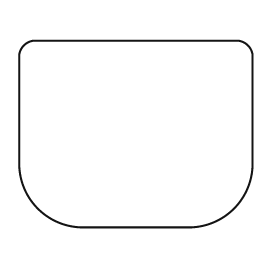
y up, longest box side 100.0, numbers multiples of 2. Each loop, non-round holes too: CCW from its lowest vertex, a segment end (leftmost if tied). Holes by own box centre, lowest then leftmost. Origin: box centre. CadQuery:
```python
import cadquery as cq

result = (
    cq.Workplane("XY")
    .moveTo(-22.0, -40.0)
    .lineTo(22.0, -40.0)
    .threePointArc((42.0, -32.0), (50.0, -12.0))
    .lineTo(50.0, 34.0)
    .threePointArc((48.0, 38.0), (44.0, 40.0))
    .lineTo(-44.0, 40.0)
    .threePointArc((-48.0, 38.0), (-50.0, 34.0))
    .lineTo(-50.0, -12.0)
    .threePointArc((-42.0, -32.0), (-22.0, -40.0))
    .close()
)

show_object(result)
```